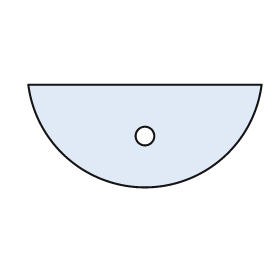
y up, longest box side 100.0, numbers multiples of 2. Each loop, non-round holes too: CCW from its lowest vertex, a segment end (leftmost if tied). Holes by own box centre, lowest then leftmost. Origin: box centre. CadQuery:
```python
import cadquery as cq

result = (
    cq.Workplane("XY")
    .moveTo(-50.0, 22.0)
    .threePointArc((0.0, -22.0), (50.0, 22.0))
    .close()
    .moveTo(0.0, 0.0)
    .circle(4.0)
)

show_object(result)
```